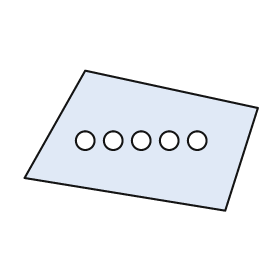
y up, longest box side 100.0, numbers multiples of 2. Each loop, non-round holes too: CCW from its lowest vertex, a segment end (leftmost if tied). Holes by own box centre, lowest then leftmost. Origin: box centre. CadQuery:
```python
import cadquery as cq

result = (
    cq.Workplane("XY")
    .moveTo(36.0, -30.0)
    .lineTo(50.0, 14.0)
    .lineTo(-24.0, 30.0)
    .lineTo(-50.0, -16.0)
    .close()
    .moveTo(-24.0, 0.0)
    .circle(4.0)
    .moveTo(-12.0, 0.0)
    .circle(4.0)
    .moveTo(0.0, 0.0)
    .circle(4.0)
    .moveTo(12.0, 0.0)
    .circle(4.0)
    .moveTo(24.0, 0.0)
    .circle(4.0)
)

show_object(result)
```